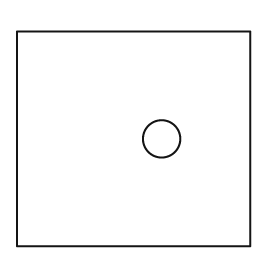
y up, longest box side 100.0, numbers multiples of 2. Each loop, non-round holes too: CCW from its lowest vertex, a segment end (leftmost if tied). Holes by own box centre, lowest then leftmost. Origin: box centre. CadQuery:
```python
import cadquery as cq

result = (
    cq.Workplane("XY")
    .moveTo(-50.0, -46.0)
    .lineTo(50.0, -46.0)
    .lineTo(50.0, 46.0)
    .lineTo(-50.0, 46.0)
    .close()
    .moveTo(12.0, 0.0)
    .circle(8.0)
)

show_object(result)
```